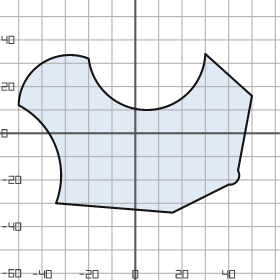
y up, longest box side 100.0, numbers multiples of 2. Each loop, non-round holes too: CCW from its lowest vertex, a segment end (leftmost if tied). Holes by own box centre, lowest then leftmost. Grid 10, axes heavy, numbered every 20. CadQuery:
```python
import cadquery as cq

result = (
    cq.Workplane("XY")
    .moveTo(16.0, -34.0)
    .lineTo(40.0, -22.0)
    .threePointArc((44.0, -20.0), (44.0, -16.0))
    .lineTo(50.0, 16.0)
    .lineTo(30.0, 34.0)
    .threePointArc((6.0, 10.0), (-20.0, 32.0))
    .threePointArc((-40.0, 30.0), (-50.0, 12.0))
    .threePointArc((-34.0, -6.0), (-34.0, -30.0))
    .close()
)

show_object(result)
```